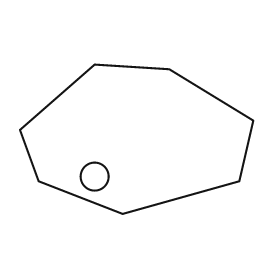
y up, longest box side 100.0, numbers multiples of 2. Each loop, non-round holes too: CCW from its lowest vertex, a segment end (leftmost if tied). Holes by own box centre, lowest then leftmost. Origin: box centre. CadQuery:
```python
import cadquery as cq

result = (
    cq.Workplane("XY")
    .moveTo(-6.0, -32.0)
    .lineTo(44.0, -18.0)
    .lineTo(50.0, 8.0)
    .lineTo(14.0, 30.0)
    .lineTo(-18.0, 32.0)
    .lineTo(-50.0, 4.0)
    .lineTo(-42.0, -18.0)
    .close()
    .moveTo(-18.0, -16.0)
    .circle(6.0)
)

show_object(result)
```